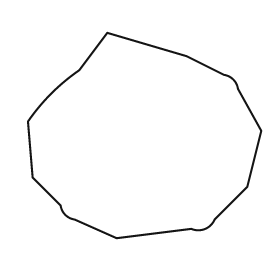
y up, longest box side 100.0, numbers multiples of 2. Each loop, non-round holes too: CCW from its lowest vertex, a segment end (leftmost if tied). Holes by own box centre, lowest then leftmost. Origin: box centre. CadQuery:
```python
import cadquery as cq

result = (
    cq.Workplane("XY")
    .moveTo(-12.0, -44.0)
    .lineTo(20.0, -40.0)
    .threePointArc((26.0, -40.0), (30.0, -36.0))
    .lineTo(44.0, -22.0)
    .lineTo(50.0, 2.0)
    .lineTo(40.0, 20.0)
    .threePointArc((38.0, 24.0), (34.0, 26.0))
    .lineTo(18.0, 34.0)
    .lineTo(-16.0, 44.0)
    .lineTo(-28.0, 28.0)
    .threePointArc((-40.0, 18.0), (-50.0, 6.0))
    .lineTo(-48.0, -18.0)
    .lineTo(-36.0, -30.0)
    .threePointArc((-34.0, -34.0), (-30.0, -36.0))
    .close()
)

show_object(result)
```